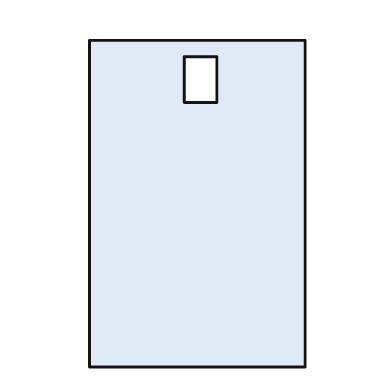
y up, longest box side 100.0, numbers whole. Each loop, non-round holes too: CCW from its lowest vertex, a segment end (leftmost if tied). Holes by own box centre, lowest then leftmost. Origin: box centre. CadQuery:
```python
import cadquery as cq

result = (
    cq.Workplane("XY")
    .moveTo(-33.0, -50.0)
    .lineTo(33.0, -50.0)
    .lineTo(33.0, 50.0)
    .lineTo(-33.0, 50.0)
    .close()
    .moveTo(-4.0, 31.0)
    .lineTo(6.0, 31.0)
    .lineTo(6.0, 45.0)
    .lineTo(-4.0, 45.0)
    .close()
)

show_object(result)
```